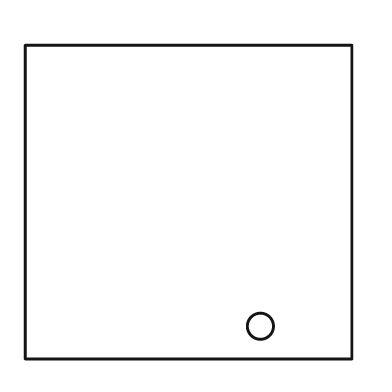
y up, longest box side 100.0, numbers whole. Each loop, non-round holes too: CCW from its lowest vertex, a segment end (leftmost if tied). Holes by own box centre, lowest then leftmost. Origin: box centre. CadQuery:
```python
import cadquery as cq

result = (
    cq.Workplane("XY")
    .moveTo(-50.0, -48.0)
    .lineTo(50.0, -48.0)
    .lineTo(50.0, 48.0)
    .lineTo(-50.0, 48.0)
    .close()
    .moveTo(22.0, -38.0)
    .circle(4.0)
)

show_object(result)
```